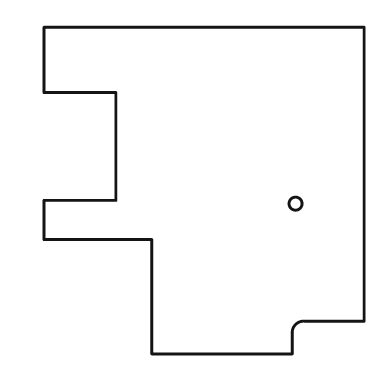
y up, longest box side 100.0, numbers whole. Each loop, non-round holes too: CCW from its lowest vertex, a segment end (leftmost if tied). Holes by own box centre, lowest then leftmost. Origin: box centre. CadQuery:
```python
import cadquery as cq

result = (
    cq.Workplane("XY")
    .moveTo(-16.0, -50.0)
    .lineTo(27.0, -50.0)
    .lineTo(27.0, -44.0)
    .threePointArc((28.0, -41.0), (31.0, -40.0))
    .lineTo(49.0, -40.0)
    .lineTo(49.0, 50.0)
    .lineTo(-49.0, 50.0)
    .lineTo(-49.0, 30.0)
    .lineTo(-27.0, 30.0)
    .lineTo(-27.0, -3.0)
    .lineTo(-49.0, -3.0)
    .lineTo(-49.0, -15.0)
    .lineTo(-16.0, -15.0)
    .close()
    .moveTo(28.0, -4.0)
    .circle(2.0)
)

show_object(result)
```